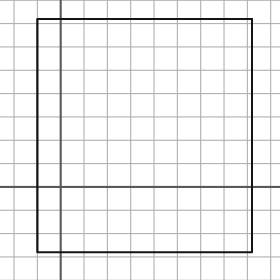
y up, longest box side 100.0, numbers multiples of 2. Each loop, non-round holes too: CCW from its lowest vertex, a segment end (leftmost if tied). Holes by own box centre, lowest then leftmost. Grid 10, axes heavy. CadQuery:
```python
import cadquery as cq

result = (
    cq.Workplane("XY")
    .moveTo(-10.0, -28.0)
    .lineTo(82.0, -28.0)
    .lineTo(82.0, 72.0)
    .lineTo(-10.0, 72.0)
    .close()
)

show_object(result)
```